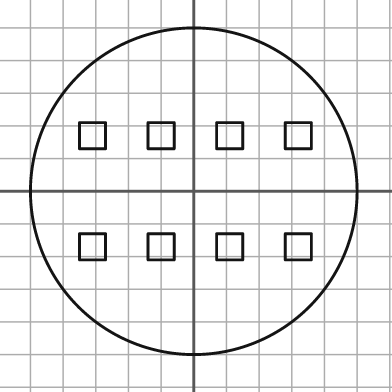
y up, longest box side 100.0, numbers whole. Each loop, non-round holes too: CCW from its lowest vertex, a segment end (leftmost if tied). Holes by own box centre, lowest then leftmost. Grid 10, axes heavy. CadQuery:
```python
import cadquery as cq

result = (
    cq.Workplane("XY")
    .moveTo(0.0, 0.0)
    .circle(50.0)
    .moveTo(-35.0, -21.0)
    .lineTo(-27.0, -21.0)
    .lineTo(-27.0, -13.0)
    .lineTo(-35.0, -13.0)
    .close()
    .moveTo(-14.0, -21.0)
    .lineTo(-6.0, -21.0)
    .lineTo(-6.0, -13.0)
    .lineTo(-14.0, -13.0)
    .close()
    .moveTo(7.0, -21.0)
    .lineTo(15.0, -21.0)
    .lineTo(15.0, -13.0)
    .lineTo(7.0, -13.0)
    .close()
    .moveTo(28.0, -21.0)
    .lineTo(36.0, -21.0)
    .lineTo(36.0, -13.0)
    .lineTo(28.0, -13.0)
    .close()
    .moveTo(-35.0, 13.0)
    .lineTo(-27.0, 13.0)
    .lineTo(-27.0, 21.0)
    .lineTo(-35.0, 21.0)
    .close()
    .moveTo(-14.0, 13.0)
    .lineTo(-6.0, 13.0)
    .lineTo(-6.0, 21.0)
    .lineTo(-14.0, 21.0)
    .close()
    .moveTo(7.0, 13.0)
    .lineTo(15.0, 13.0)
    .lineTo(15.0, 21.0)
    .lineTo(7.0, 21.0)
    .close()
    .moveTo(28.0, 13.0)
    .lineTo(36.0, 13.0)
    .lineTo(36.0, 21.0)
    .lineTo(28.0, 21.0)
    .close()
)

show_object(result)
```